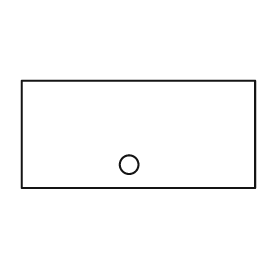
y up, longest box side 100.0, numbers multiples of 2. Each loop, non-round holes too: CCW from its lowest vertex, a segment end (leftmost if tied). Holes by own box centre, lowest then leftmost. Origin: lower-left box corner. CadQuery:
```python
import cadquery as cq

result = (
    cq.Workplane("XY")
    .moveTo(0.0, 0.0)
    .lineTo(100.0, 0.0)
    .lineTo(100.0, 46.0)
    .lineTo(0.0, 46.0)
    .close()
    .moveTo(46.0, 10.0)
    .circle(4.0)
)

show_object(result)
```